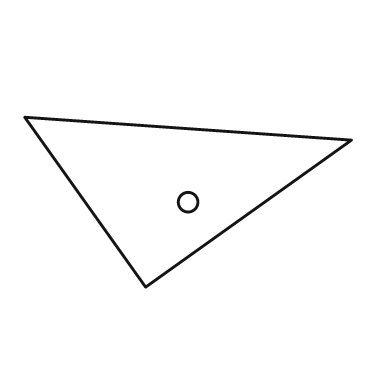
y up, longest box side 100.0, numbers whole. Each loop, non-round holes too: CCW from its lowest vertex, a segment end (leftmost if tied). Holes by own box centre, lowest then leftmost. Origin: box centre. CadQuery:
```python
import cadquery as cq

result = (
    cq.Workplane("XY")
    .moveTo(-13.0, -26.0)
    .lineTo(50.0, 19.0)
    .lineTo(-50.0, 26.0)
    .close()
    .moveTo(0.0, 0.0)
    .circle(3.0)
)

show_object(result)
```